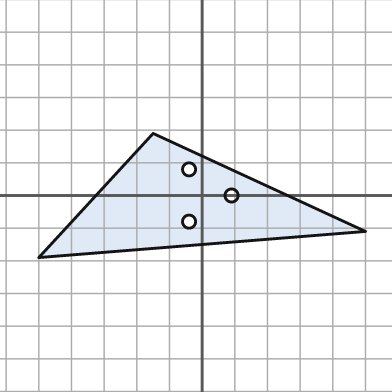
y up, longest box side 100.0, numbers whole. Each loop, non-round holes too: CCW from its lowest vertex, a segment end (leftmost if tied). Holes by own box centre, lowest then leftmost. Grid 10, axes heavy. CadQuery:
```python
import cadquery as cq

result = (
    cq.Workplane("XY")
    .moveTo(-50.0, -19.0)
    .lineTo(50.0, -11.0)
    .lineTo(-15.0, 19.0)
    .close()
    .moveTo(-4.0, -8.0)
    .circle(2.0)
    .moveTo(9.0, 0.0)
    .circle(2.0)
    .moveTo(-4.0, 8.0)
    .circle(2.0)
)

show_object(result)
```